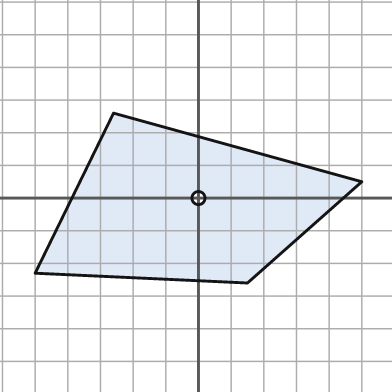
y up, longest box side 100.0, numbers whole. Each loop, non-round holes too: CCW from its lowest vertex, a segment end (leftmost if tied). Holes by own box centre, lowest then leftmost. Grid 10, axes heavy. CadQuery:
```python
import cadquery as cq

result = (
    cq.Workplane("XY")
    .moveTo(15.0, -26.0)
    .lineTo(50.0, 5.0)
    .lineTo(-26.0, 26.0)
    .lineTo(-50.0, -23.0)
    .close()
    .moveTo(0.0, 0.0)
    .circle(2.0)
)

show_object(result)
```